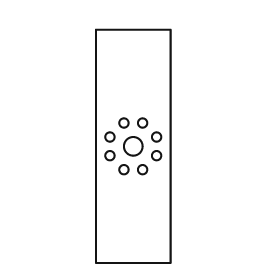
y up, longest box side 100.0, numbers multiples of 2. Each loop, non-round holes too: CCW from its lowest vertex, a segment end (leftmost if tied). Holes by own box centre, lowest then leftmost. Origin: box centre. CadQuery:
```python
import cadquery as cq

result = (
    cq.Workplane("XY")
    .moveTo(-16.0, -50.0)
    .lineTo(16.0, -50.0)
    .lineTo(16.0, 50.0)
    .lineTo(-16.0, 50.0)
    .close()
    .moveTo(-4.0, -10.0)
    .circle(2.0)
    .moveTo(4.0, -10.0)
    .circle(2.0)
    .moveTo(-10.0, -4.0)
    .circle(2.0)
    .moveTo(10.0, -4.0)
    .circle(2.0)
    .moveTo(0.0, 0.0)
    .circle(4.0)
    .moveTo(-10.0, 4.0)
    .circle(2.0)
    .moveTo(10.0, 4.0)
    .circle(2.0)
    .moveTo(-4.0, 10.0)
    .circle(2.0)
    .moveTo(4.0, 10.0)
    .circle(2.0)
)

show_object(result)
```